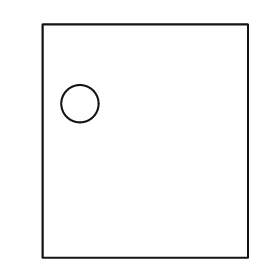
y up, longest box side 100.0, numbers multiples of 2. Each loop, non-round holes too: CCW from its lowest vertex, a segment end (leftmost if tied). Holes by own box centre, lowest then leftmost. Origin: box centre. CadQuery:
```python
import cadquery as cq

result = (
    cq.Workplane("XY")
    .moveTo(-44.0, -50.0)
    .lineTo(44.0, -50.0)
    .lineTo(44.0, 50.0)
    .lineTo(-44.0, 50.0)
    .close()
    .moveTo(-28.0, 16.0)
    .circle(8.0)
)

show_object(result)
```